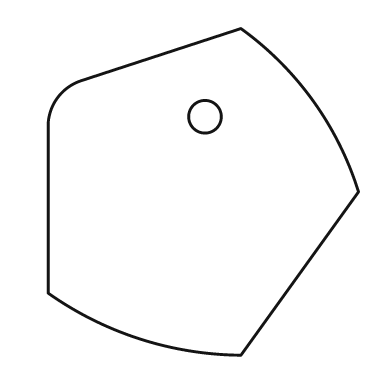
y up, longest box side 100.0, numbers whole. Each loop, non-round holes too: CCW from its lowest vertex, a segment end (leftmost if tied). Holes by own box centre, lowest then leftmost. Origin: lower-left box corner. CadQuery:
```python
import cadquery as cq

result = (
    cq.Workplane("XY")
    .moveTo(59.0, 0.0)
    .lineTo(95.0, 50.0)
    .threePointArc((81.0, 78.0), (59.0, 100.0))
    .lineTo(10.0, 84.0)
    .threePointArc((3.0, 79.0), (0.0, 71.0))
    .lineTo(0.0, 19.0)
    .threePointArc((28.0, 5.0), (59.0, 0.0))
    .close()
    .moveTo(48.0, 73.0)
    .circle(5.0)
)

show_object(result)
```